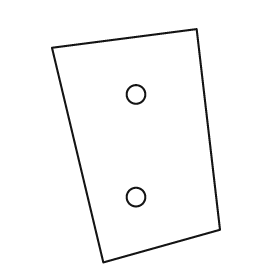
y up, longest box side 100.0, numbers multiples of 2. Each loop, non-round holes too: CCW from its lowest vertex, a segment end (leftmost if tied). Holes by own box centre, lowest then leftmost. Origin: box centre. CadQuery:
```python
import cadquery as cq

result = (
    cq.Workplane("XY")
    .moveTo(-14.0, -50.0)
    .lineTo(36.0, -36.0)
    .lineTo(26.0, 50.0)
    .lineTo(-36.0, 42.0)
    .close()
    .moveTo(0.0, -22.0)
    .circle(4.0)
    .moveTo(0.0, 22.0)
    .circle(4.0)
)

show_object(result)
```